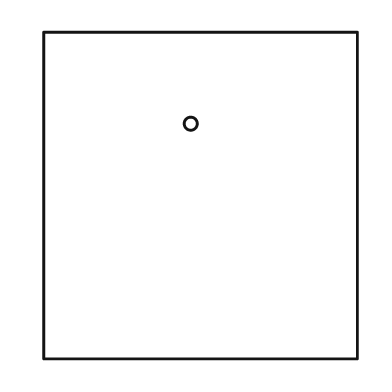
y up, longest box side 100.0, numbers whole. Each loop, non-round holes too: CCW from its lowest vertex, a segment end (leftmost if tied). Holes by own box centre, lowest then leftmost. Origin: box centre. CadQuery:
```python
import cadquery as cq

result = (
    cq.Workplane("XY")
    .moveTo(-48.0, -50.0)
    .lineTo(48.0, -50.0)
    .lineTo(48.0, 50.0)
    .lineTo(-48.0, 50.0)
    .close()
    .moveTo(-3.0, 22.0)
    .circle(2.0)
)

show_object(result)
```